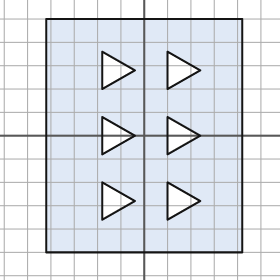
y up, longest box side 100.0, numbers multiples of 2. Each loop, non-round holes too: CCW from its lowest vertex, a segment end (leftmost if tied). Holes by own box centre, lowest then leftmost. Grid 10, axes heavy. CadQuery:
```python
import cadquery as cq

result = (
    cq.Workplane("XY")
    .moveTo(-42.0, -50.0)
    .lineTo(42.0, -50.0)
    .lineTo(42.0, 50.0)
    .lineTo(-42.0, 50.0)
    .close()
    .moveTo(-18.0, -36.0)
    .lineTo(-4.0, -28.0)
    .lineTo(-18.0, -20.0)
    .close()
    .moveTo(10.0, -36.0)
    .lineTo(24.0, -28.0)
    .lineTo(10.0, -20.0)
    .close()
    .moveTo(-18.0, -8.0)
    .lineTo(-4.0, 0.0)
    .lineTo(-18.0, 8.0)
    .close()
    .moveTo(10.0, -8.0)
    .lineTo(24.0, 0.0)
    .lineTo(10.0, 8.0)
    .close()
    .moveTo(-18.0, 20.0)
    .lineTo(-4.0, 28.0)
    .lineTo(-18.0, 36.0)
    .close()
    .moveTo(10.0, 20.0)
    .lineTo(24.0, 28.0)
    .lineTo(10.0, 36.0)
    .close()
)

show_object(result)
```